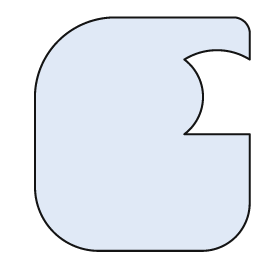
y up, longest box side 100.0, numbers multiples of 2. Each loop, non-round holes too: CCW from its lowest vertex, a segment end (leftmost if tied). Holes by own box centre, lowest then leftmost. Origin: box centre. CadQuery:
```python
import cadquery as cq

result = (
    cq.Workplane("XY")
    .moveTo(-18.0, -50.0)
    .lineTo(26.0, -50.0)
    .threePointArc((40.0, -44.0), (46.0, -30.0))
    .lineTo(46.0, 0.0)
    .lineTo(18.0, 0.0)
    .threePointArc((26.0, 16.0), (18.0, 32.0))
    .threePointArc((32.0, 36.0), (46.0, 32.0))
    .lineTo(46.0, 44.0)
    .threePointArc((44.0, 48.0), (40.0, 50.0))
    .lineTo(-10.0, 50.0)
    .threePointArc((-36.0, 40.0), (-46.0, 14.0))
    .lineTo(-46.0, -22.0)
    .threePointArc((-38.0, -42.0), (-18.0, -50.0))
    .close()
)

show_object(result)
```